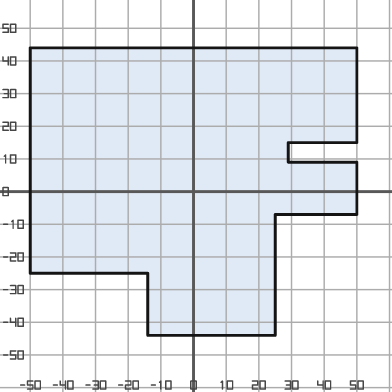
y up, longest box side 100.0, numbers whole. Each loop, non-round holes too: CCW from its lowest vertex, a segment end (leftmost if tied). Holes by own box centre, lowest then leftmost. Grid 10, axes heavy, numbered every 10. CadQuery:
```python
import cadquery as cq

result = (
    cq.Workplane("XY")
    .moveTo(-14.0, -44.0)
    .lineTo(25.0, -44.0)
    .lineTo(25.0, -7.0)
    .lineTo(50.0, -7.0)
    .lineTo(50.0, 9.0)
    .lineTo(29.0, 9.0)
    .lineTo(29.0, 15.0)
    .lineTo(50.0, 15.0)
    .lineTo(50.0, 44.0)
    .lineTo(-50.0, 44.0)
    .lineTo(-50.0, -25.0)
    .lineTo(-14.0, -25.0)
    .close()
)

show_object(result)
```